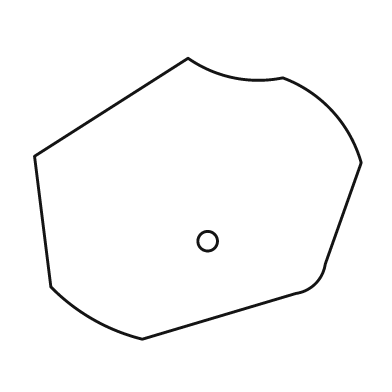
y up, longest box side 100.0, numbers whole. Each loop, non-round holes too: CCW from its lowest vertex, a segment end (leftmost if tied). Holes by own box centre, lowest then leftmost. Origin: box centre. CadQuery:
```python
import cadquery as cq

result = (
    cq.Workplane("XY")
    .moveTo(-17.0, -43.0)
    .lineTo(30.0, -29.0)
    .threePointArc((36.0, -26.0), (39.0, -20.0))
    .lineTo(50.0, 11.0)
    .threePointArc((41.0, 27.0), (26.0, 37.0))
    .threePointArc((11.0, 37.0), (-3.0, 43.0))
    .lineTo(-50.0, 13.0)
    .lineTo(-45.0, -27.0)
    .threePointArc((-32.0, -37.0), (-17.0, -43.0))
    .close()
    .moveTo(3.0, -13.0)
    .circle(3.0)
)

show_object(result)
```